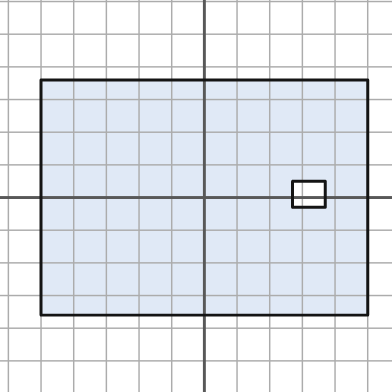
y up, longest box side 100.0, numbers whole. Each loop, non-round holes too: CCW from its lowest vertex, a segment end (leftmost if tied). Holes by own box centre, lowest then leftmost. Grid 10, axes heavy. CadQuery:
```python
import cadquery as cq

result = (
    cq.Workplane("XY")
    .moveTo(-50.0, -36.0)
    .lineTo(50.0, -36.0)
    .lineTo(50.0, 36.0)
    .lineTo(-50.0, 36.0)
    .close()
    .moveTo(27.0, -3.0)
    .lineTo(37.0, -3.0)
    .lineTo(37.0, 5.0)
    .lineTo(27.0, 5.0)
    .close()
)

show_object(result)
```